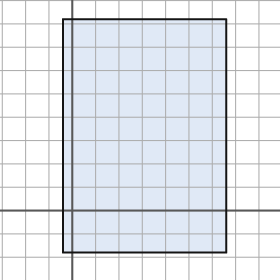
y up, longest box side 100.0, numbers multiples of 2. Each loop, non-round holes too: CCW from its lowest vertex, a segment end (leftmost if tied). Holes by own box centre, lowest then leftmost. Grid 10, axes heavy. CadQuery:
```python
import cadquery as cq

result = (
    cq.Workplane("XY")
    .moveTo(-4.0, -18.0)
    .lineTo(66.0, -18.0)
    .lineTo(66.0, 82.0)
    .lineTo(-4.0, 82.0)
    .close()
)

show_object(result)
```